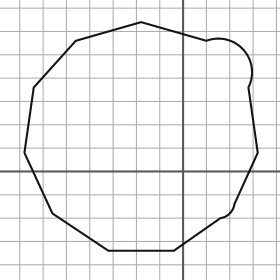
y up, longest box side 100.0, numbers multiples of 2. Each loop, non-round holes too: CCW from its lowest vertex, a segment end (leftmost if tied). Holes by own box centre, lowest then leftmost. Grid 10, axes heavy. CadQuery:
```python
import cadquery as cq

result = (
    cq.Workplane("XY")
    .moveTo(-32.0, -34.0)
    .lineTo(-4.0, -34.0)
    .lineTo(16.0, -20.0)
    .threePointArc((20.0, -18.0), (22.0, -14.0))
    .lineTo(32.0, 8.0)
    .lineTo(28.0, 36.0)
    .threePointArc((26.0, 52.0), (10.0, 56.0))
    .lineTo(-18.0, 64.0)
    .lineTo(-46.0, 56.0)
    .lineTo(-64.0, 36.0)
    .lineTo(-68.0, 8.0)
    .lineTo(-56.0, -18.0)
    .close()
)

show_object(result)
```